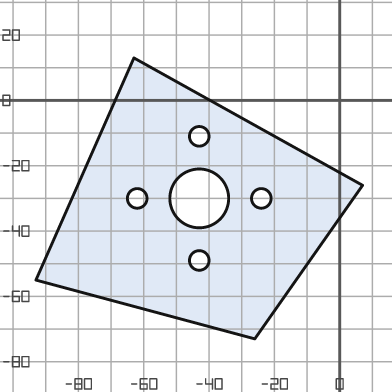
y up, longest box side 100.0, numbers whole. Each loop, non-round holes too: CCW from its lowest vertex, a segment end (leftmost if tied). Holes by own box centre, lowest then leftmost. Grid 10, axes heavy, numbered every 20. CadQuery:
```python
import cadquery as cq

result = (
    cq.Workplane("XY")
    .moveTo(-26.0, -73.0)
    .lineTo(7.0, -26.0)
    .lineTo(-63.0, 13.0)
    .lineTo(-93.0, -55.0)
    .close()
    .moveTo(-43.0, -49.0)
    .circle(3.0)
    .moveTo(-62.0, -30.0)
    .circle(3.0)
    .moveTo(-43.0, -30.0)
    .circle(9.0)
    .moveTo(-24.0, -30.0)
    .circle(3.0)
    .moveTo(-43.0, -11.0)
    .circle(3.0)
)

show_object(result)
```